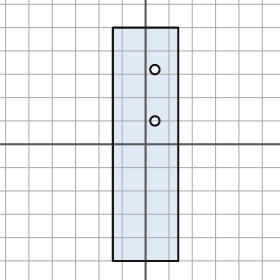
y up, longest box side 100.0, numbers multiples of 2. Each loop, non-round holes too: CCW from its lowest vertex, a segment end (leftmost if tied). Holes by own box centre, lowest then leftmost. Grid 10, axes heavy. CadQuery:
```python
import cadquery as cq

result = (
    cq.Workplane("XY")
    .moveTo(-14.0, -50.0)
    .lineTo(14.0, -50.0)
    .lineTo(14.0, 50.0)
    .lineTo(-14.0, 50.0)
    .close()
    .moveTo(4.0, 10.0)
    .circle(2.0)
    .moveTo(4.0, 32.0)
    .circle(2.0)
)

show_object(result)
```